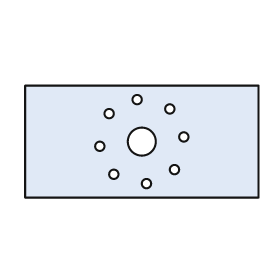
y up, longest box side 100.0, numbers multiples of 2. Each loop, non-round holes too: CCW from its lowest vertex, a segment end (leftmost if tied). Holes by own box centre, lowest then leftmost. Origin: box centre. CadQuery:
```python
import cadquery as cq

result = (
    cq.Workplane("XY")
    .moveTo(-50.0, -24.0)
    .lineTo(50.0, -24.0)
    .lineTo(50.0, 24.0)
    .lineTo(-50.0, 24.0)
    .close()
    .moveTo(2.0, -18.0)
    .circle(2.0)
    .moveTo(-12.0, -14.0)
    .circle(2.0)
    .moveTo(14.0, -12.0)
    .circle(2.0)
    .moveTo(-18.0, -2.0)
    .circle(2.0)
    .moveTo(0.0, 0.0)
    .circle(6.0)
    .moveTo(18.0, 2.0)
    .circle(2.0)
    .moveTo(-14.0, 12.0)
    .circle(2.0)
    .moveTo(12.0, 14.0)
    .circle(2.0)
    .moveTo(-2.0, 18.0)
    .circle(2.0)
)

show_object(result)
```